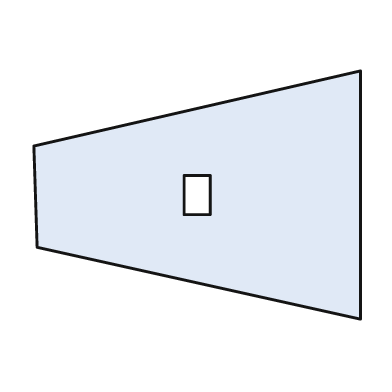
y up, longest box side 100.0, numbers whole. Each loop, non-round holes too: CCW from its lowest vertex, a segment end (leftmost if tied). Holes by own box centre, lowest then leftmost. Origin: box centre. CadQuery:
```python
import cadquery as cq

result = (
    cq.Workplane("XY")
    .moveTo(50.0, -38.0)
    .lineTo(50.0, 38.0)
    .lineTo(-50.0, 15.0)
    .lineTo(-49.0, -16.0)
    .close()
    .moveTo(-4.0, -6.0)
    .lineTo(4.0, -6.0)
    .lineTo(4.0, 6.0)
    .lineTo(-4.0, 6.0)
    .close()
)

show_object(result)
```